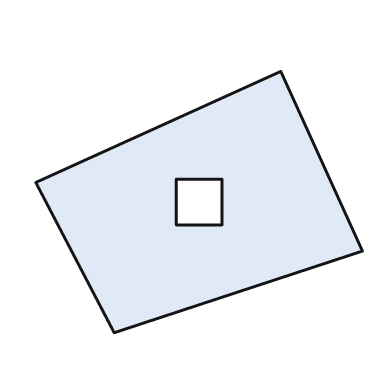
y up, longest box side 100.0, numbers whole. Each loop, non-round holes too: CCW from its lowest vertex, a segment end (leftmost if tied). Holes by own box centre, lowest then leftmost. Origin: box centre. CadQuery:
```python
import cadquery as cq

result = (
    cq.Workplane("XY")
    .moveTo(-26.0, -40.0)
    .lineTo(50.0, -15.0)
    .lineTo(25.0, 40.0)
    .lineTo(-50.0, 6.0)
    .close()
    .moveTo(-7.0, -7.0)
    .lineTo(7.0, -7.0)
    .lineTo(7.0, 7.0)
    .lineTo(-7.0, 7.0)
    .close()
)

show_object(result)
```